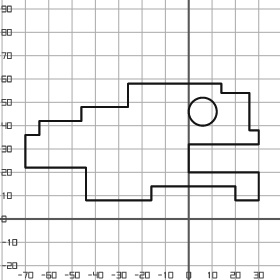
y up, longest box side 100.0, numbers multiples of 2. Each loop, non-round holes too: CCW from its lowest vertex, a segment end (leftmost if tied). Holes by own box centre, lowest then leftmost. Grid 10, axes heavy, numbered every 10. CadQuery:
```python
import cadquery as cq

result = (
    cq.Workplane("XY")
    .moveTo(-44.0, 8.0)
    .lineTo(-16.0, 8.0)
    .lineTo(-16.0, 14.0)
    .lineTo(20.0, 14.0)
    .lineTo(20.0, 8.0)
    .lineTo(30.0, 8.0)
    .lineTo(30.0, 20.0)
    .lineTo(0.0, 20.0)
    .lineTo(0.0, 32.0)
    .lineTo(30.0, 32.0)
    .lineTo(30.0, 38.0)
    .lineTo(26.0, 38.0)
    .lineTo(26.0, 54.0)
    .lineTo(14.0, 54.0)
    .lineTo(14.0, 58.0)
    .lineTo(-26.0, 58.0)
    .lineTo(-26.0, 48.0)
    .lineTo(-46.0, 48.0)
    .lineTo(-46.0, 42.0)
    .lineTo(-64.0, 42.0)
    .lineTo(-64.0, 36.0)
    .lineTo(-70.0, 36.0)
    .lineTo(-70.0, 22.0)
    .lineTo(-44.0, 22.0)
    .close()
    .moveTo(6.0, 46.0)
    .circle(6.0)
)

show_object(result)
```